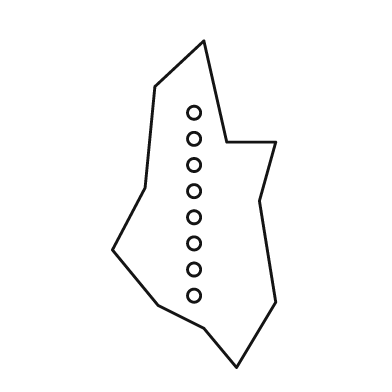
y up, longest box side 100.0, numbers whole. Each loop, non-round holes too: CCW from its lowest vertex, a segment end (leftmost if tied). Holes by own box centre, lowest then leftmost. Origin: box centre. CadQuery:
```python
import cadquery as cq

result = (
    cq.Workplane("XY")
    .moveTo(13.0, -50.0)
    .lineTo(25.0, -30.0)
    .lineTo(20.0, 1.0)
    .lineTo(25.0, 19.0)
    .lineTo(10.0, 19.0)
    .lineTo(3.0, 50.0)
    .lineTo(-12.0, 36.0)
    .lineTo(-15.0, 5.0)
    .lineTo(-25.0, -14.0)
    .lineTo(-11.0, -31.0)
    .lineTo(3.0, -38.0)
    .close()
    .moveTo(0.0, -28.0)
    .circle(2.0)
    .moveTo(0.0, -20.0)
    .circle(2.0)
    .moveTo(0.0, -12.0)
    .circle(2.0)
    .moveTo(0.0, -4.0)
    .circle(2.0)
    .moveTo(0.0, 4.0)
    .circle(2.0)
    .moveTo(0.0, 12.0)
    .circle(2.0)
    .moveTo(0.0, 20.0)
    .circle(2.0)
    .moveTo(0.0, 28.0)
    .circle(2.0)
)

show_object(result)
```